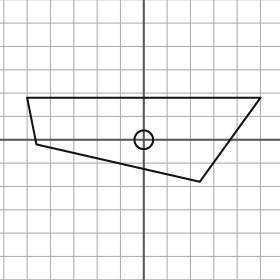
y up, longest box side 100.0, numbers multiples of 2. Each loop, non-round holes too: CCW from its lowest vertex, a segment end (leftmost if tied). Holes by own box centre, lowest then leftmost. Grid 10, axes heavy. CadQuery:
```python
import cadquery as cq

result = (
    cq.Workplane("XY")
    .moveTo(24.0, -18.0)
    .lineTo(50.0, 18.0)
    .lineTo(-50.0, 18.0)
    .lineTo(-46.0, -2.0)
    .close()
    .moveTo(0.0, 0.0)
    .circle(4.0)
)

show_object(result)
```